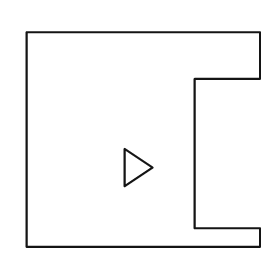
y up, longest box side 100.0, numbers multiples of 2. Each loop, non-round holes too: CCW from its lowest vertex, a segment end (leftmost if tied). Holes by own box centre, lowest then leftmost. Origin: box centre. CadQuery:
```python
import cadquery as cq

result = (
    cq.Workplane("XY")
    .moveTo(-50.0, -46.0)
    .lineTo(50.0, -46.0)
    .lineTo(50.0, -38.0)
    .lineTo(22.0, -38.0)
    .lineTo(22.0, 26.0)
    .lineTo(50.0, 26.0)
    .lineTo(50.0, 46.0)
    .lineTo(-50.0, 46.0)
    .close()
    .moveTo(-8.0, -20.0)
    .lineTo(4.0, -12.0)
    .lineTo(-8.0, -4.0)
    .close()
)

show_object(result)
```